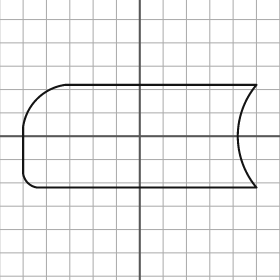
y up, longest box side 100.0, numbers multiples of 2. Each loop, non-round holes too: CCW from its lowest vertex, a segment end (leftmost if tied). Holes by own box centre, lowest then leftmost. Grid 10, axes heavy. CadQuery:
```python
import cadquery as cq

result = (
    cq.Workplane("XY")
    .moveTo(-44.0, -22.0)
    .lineTo(50.0, -22.0)
    .threePointArc((42.0, 0.0), (50.0, 22.0))
    .lineTo(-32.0, 22.0)
    .threePointArc((-44.0, 16.0), (-50.0, 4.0))
    .lineTo(-50.0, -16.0)
    .threePointArc((-48.0, -20.0), (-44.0, -22.0))
    .close()
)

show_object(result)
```